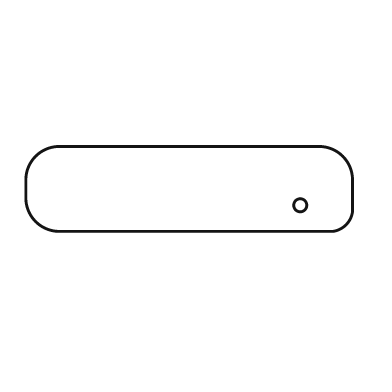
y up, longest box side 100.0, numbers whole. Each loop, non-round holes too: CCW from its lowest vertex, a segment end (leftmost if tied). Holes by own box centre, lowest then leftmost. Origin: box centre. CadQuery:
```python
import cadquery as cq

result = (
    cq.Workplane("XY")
    .moveTo(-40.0, -13.0)
    .lineTo(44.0, -13.0)
    .threePointArc((48.0, -11.0), (50.0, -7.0))
    .lineTo(50.0, 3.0)
    .threePointArc((47.0, 10.0), (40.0, 13.0))
    .lineTo(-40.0, 13.0)
    .threePointArc((-47.0, 10.0), (-50.0, 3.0))
    .lineTo(-50.0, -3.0)
    .threePointArc((-47.0, -10.0), (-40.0, -13.0))
    .close()
    .moveTo(34.0, -5.0)
    .circle(2.0)
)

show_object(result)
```